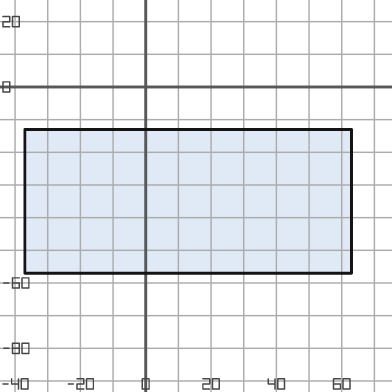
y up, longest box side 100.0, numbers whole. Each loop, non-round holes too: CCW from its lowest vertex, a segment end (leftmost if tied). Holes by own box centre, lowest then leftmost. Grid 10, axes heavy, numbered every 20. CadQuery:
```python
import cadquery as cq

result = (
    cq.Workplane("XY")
    .moveTo(-37.0, -57.0)
    .lineTo(63.0, -57.0)
    .lineTo(63.0, -13.0)
    .lineTo(-37.0, -13.0)
    .close()
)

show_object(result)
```